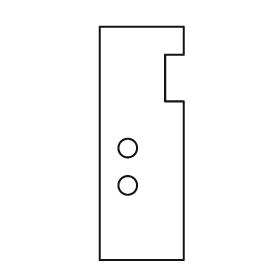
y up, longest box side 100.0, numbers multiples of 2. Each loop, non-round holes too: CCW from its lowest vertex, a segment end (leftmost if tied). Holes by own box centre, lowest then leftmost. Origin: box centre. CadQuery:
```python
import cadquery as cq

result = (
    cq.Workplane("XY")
    .moveTo(-18.0, -50.0)
    .lineTo(18.0, -50.0)
    .lineTo(18.0, 18.0)
    .lineTo(10.0, 18.0)
    .lineTo(10.0, 38.0)
    .lineTo(18.0, 38.0)
    .lineTo(18.0, 50.0)
    .lineTo(-18.0, 50.0)
    .close()
    .moveTo(-6.0, -18.0)
    .circle(4.0)
    .moveTo(-6.0, -2.0)
    .circle(4.0)
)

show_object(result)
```